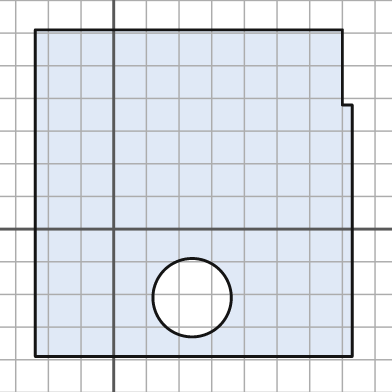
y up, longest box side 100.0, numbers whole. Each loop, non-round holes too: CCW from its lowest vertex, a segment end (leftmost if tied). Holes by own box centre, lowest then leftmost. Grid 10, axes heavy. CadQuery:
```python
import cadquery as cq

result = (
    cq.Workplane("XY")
    .moveTo(-24.0, -39.0)
    .lineTo(73.0, -39.0)
    .lineTo(73.0, 38.0)
    .lineTo(70.0, 38.0)
    .lineTo(70.0, 61.0)
    .lineTo(-24.0, 61.0)
    .close()
    .moveTo(24.0, -21.0)
    .circle(12.0)
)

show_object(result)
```